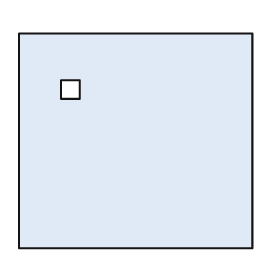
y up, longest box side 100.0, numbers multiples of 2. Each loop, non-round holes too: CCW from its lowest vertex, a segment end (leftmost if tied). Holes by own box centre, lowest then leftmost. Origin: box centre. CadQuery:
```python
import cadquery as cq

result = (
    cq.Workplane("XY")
    .moveTo(-50.0, -46.0)
    .lineTo(50.0, -46.0)
    .lineTo(50.0, 46.0)
    .lineTo(-50.0, 46.0)
    .close()
    .moveTo(-32.0, 18.0)
    .lineTo(-24.0, 18.0)
    .lineTo(-24.0, 26.0)
    .lineTo(-32.0, 26.0)
    .close()
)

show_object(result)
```